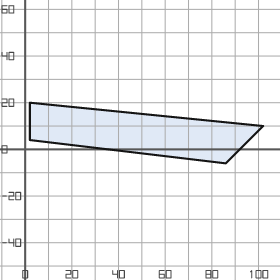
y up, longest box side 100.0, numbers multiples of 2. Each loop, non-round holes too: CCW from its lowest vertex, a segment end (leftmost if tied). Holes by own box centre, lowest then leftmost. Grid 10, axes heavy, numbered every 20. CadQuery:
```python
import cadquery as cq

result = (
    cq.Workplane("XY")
    .moveTo(86.0, -6.0)
    .lineTo(102.0, 10.0)
    .lineTo(2.0, 20.0)
    .lineTo(2.0, 4.0)
    .close()
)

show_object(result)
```